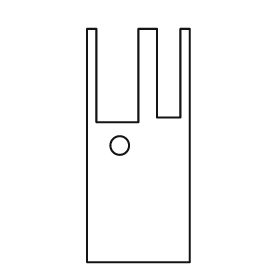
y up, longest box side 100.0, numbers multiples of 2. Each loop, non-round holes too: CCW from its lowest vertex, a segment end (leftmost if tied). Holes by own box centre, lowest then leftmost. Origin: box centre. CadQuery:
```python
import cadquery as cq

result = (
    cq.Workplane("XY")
    .moveTo(-22.0, -50.0)
    .lineTo(22.0, -50.0)
    .lineTo(22.0, 50.0)
    .lineTo(18.0, 50.0)
    .lineTo(18.0, 12.0)
    .lineTo(8.0, 12.0)
    .lineTo(8.0, 50.0)
    .lineTo(0.0, 50.0)
    .lineTo(0.0, 10.0)
    .lineTo(-18.0, 10.0)
    .lineTo(-18.0, 50.0)
    .lineTo(-22.0, 50.0)
    .close()
    .moveTo(-8.0, 0.0)
    .circle(4.0)
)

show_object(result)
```